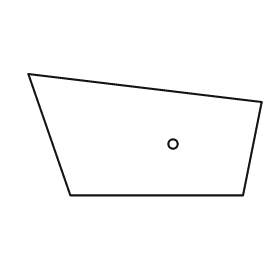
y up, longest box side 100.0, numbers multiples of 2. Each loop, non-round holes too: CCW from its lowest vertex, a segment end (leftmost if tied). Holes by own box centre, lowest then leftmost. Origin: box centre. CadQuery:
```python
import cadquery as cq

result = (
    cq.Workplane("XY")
    .moveTo(-32.0, -26.0)
    .lineTo(42.0, -26.0)
    .lineTo(50.0, 14.0)
    .lineTo(-50.0, 26.0)
    .close()
    .moveTo(12.0, -4.0)
    .circle(2.0)
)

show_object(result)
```